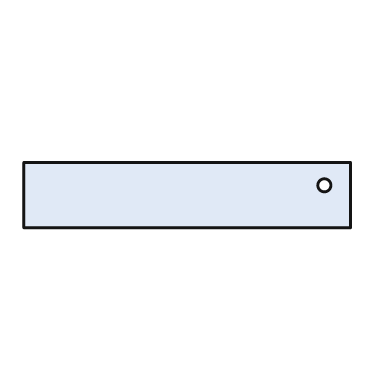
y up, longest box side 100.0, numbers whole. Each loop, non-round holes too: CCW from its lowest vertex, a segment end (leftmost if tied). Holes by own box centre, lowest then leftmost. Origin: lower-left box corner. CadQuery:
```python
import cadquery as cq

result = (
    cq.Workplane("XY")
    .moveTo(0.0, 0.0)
    .lineTo(100.0, 0.0)
    .lineTo(100.0, 20.0)
    .lineTo(0.0, 20.0)
    .close()
    .moveTo(92.0, 13.0)
    .circle(2.0)
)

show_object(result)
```